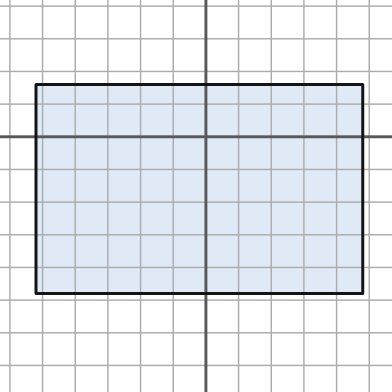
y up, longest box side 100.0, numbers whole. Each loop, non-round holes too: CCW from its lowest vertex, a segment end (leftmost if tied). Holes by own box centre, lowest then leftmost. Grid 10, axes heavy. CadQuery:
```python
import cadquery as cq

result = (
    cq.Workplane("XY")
    .moveTo(-52.0, -48.0)
    .lineTo(48.0, -48.0)
    .lineTo(48.0, 16.0)
    .lineTo(-52.0, 16.0)
    .close()
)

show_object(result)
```